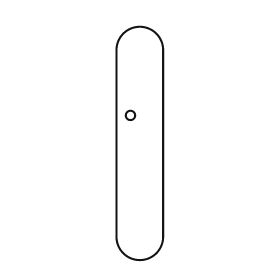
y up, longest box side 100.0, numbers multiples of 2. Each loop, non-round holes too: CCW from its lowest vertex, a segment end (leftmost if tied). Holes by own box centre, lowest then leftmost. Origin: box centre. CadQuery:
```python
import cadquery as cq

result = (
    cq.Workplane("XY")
    .moveTo(-10.0, -40.0)
    .threePointArc((0.0, -50.0), (10.0, -40.0))
    .lineTo(10.0, 40.0)
    .threePointArc((0.0, 50.0), (-10.0, 40.0))
    .close()
    .moveTo(-4.0, 12.0)
    .circle(2.0)
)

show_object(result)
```